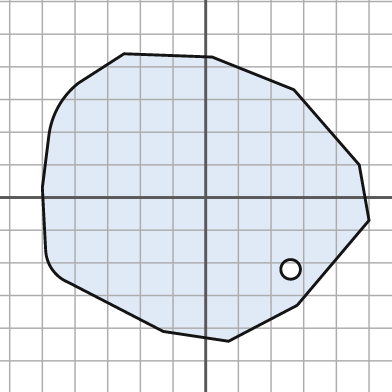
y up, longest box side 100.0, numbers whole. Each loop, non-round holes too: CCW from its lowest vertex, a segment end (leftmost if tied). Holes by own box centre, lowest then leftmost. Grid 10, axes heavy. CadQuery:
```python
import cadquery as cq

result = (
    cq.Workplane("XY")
    .moveTo(7.0, -44.0)
    .lineTo(28.0, -33.0)
    .lineTo(50.0, -7.0)
    .lineTo(47.0, 10.0)
    .lineTo(27.0, 33.0)
    .lineTo(2.0, 43.0)
    .lineTo(-25.0, 44.0)
    .lineTo(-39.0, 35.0)
    .threePointArc((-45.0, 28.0), (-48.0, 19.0))
    .lineTo(-50.0, 3.0)
    .lineTo(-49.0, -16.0)
    .threePointArc((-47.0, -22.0), (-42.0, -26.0))
    .lineTo(-13.0, -41.0)
    .close()
    .moveTo(26.0, -22.0)
    .circle(3.0)
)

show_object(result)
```